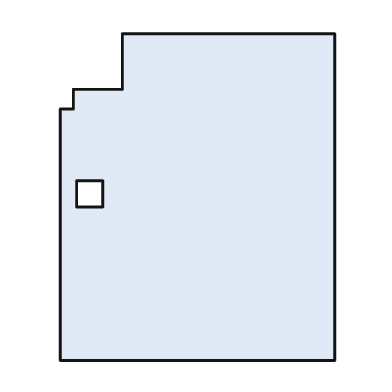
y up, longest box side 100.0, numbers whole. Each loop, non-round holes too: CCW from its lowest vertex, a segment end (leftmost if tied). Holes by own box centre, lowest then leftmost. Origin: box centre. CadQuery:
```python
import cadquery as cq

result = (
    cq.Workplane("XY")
    .moveTo(-42.0, -50.0)
    .lineTo(42.0, -50.0)
    .lineTo(42.0, 50.0)
    .lineTo(-23.0, 50.0)
    .lineTo(-23.0, 33.0)
    .lineTo(-38.0, 33.0)
    .lineTo(-38.0, 27.0)
    .lineTo(-42.0, 27.0)
    .close()
    .moveTo(-37.0, -3.0)
    .lineTo(-29.0, -3.0)
    .lineTo(-29.0, 5.0)
    .lineTo(-37.0, 5.0)
    .close()
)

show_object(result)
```